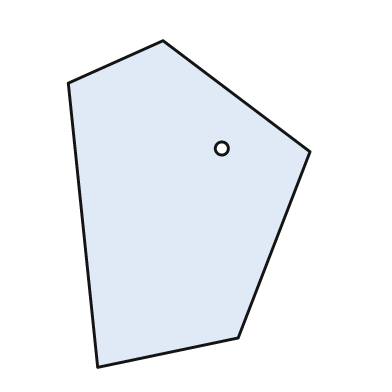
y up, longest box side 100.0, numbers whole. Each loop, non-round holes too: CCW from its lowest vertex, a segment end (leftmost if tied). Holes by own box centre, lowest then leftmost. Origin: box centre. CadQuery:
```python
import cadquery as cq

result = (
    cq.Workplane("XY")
    .moveTo(-28.0, -50.0)
    .lineTo(15.0, -41.0)
    .lineTo(37.0, 16.0)
    .lineTo(-8.0, 50.0)
    .lineTo(-37.0, 37.0)
    .close()
    .moveTo(10.0, 17.0)
    .circle(2.0)
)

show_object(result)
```